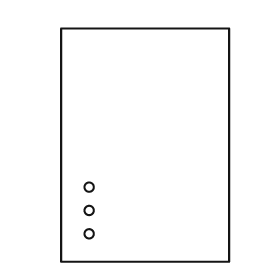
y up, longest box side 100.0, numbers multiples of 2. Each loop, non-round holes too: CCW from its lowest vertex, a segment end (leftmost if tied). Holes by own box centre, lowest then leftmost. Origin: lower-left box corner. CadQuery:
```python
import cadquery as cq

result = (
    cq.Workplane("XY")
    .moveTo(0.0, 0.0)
    .lineTo(72.0, 0.0)
    .lineTo(72.0, 100.0)
    .lineTo(0.0, 100.0)
    .close()
    .moveTo(12.0, 12.0)
    .circle(2.0)
    .moveTo(12.0, 22.0)
    .circle(2.0)
    .moveTo(12.0, 32.0)
    .circle(2.0)
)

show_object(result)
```